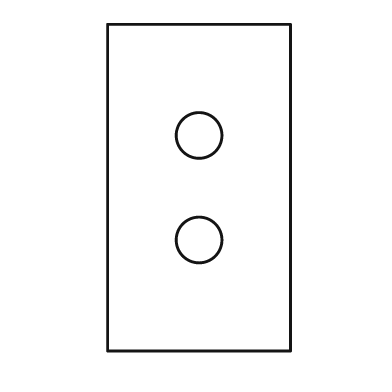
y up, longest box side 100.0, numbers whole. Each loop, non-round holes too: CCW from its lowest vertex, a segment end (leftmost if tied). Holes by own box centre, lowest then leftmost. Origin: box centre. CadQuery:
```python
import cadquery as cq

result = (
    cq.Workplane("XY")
    .moveTo(-28.0, -50.0)
    .lineTo(28.0, -50.0)
    .lineTo(28.0, 50.0)
    .lineTo(-28.0, 50.0)
    .close()
    .moveTo(0.0, -16.0)
    .circle(7.0)
    .moveTo(0.0, 16.0)
    .circle(7.0)
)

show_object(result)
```